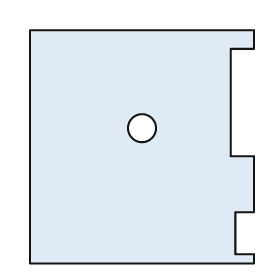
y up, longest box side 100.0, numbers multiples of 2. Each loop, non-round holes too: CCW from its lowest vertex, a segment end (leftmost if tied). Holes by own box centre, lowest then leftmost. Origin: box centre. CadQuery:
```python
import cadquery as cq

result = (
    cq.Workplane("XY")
    .moveTo(-48.0, -50.0)
    .lineTo(48.0, -50.0)
    .lineTo(48.0, -46.0)
    .lineTo(40.0, -46.0)
    .lineTo(40.0, -28.0)
    .lineTo(48.0, -28.0)
    .lineTo(48.0, -4.0)
    .lineTo(38.0, -4.0)
    .lineTo(38.0, 42.0)
    .lineTo(48.0, 42.0)
    .lineTo(48.0, 50.0)
    .lineTo(-48.0, 50.0)
    .close()
    .moveTo(0.0, 8.0)
    .circle(6.0)
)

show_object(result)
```